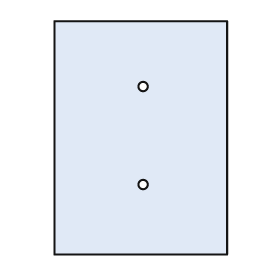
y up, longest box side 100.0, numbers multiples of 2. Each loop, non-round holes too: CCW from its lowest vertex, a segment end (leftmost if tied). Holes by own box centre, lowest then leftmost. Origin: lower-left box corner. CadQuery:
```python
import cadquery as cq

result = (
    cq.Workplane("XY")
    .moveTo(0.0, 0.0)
    .lineTo(74.0, 0.0)
    .lineTo(74.0, 100.0)
    .lineTo(0.0, 100.0)
    .close()
    .moveTo(38.0, 30.0)
    .circle(2.0)
    .moveTo(38.0, 72.0)
    .circle(2.0)
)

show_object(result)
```